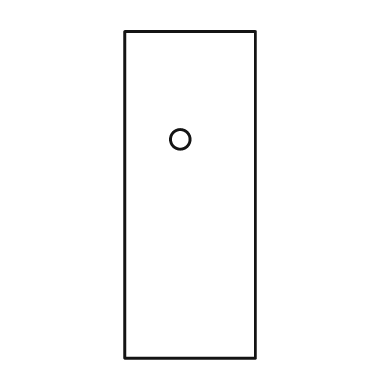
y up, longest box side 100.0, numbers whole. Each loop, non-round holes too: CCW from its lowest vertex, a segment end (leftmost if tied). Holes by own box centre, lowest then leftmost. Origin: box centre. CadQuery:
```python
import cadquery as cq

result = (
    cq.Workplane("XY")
    .moveTo(-20.0, -50.0)
    .lineTo(20.0, -50.0)
    .lineTo(20.0, 50.0)
    .lineTo(-20.0, 50.0)
    .close()
    .moveTo(-3.0, 17.0)
    .circle(3.0)
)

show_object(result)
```